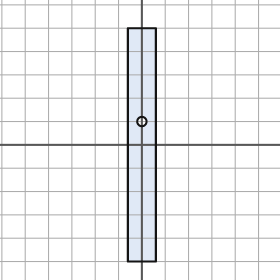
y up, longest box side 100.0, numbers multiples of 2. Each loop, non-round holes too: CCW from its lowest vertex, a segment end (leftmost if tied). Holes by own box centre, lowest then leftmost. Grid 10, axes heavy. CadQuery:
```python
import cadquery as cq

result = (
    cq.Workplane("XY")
    .moveTo(-6.0, -50.0)
    .lineTo(6.0, -50.0)
    .lineTo(6.0, 50.0)
    .lineTo(-6.0, 50.0)
    .close()
    .moveTo(0.0, 10.0)
    .circle(2.0)
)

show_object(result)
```